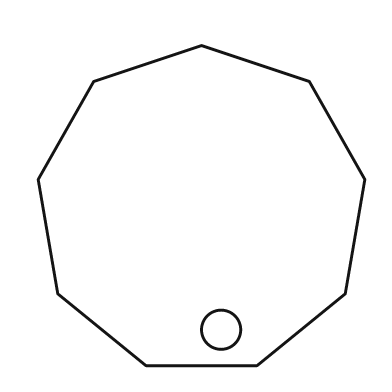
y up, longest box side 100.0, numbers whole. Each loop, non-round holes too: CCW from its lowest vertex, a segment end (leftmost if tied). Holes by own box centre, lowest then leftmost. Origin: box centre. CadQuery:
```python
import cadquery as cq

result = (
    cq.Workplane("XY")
    .moveTo(-17.0, -49.0)
    .lineTo(17.0, -49.0)
    .lineTo(44.0, -27.0)
    .lineTo(50.0, 8.0)
    .lineTo(33.0, 38.0)
    .lineTo(0.0, 49.0)
    .lineTo(-33.0, 38.0)
    .lineTo(-50.0, 8.0)
    .lineTo(-44.0, -27.0)
    .close()
    .moveTo(6.0, -38.0)
    .circle(6.0)
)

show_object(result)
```